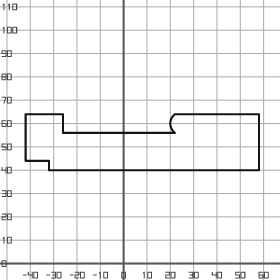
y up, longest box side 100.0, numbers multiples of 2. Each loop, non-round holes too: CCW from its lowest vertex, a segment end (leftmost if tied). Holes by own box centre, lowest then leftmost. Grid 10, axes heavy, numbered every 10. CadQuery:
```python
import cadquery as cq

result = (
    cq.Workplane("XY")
    .moveTo(-32.0, 40.0)
    .lineTo(58.0, 40.0)
    .lineTo(58.0, 64.0)
    .lineTo(22.0, 64.0)
    .threePointArc((20.0, 60.0), (22.0, 56.0))
    .lineTo(-26.0, 56.0)
    .lineTo(-26.0, 64.0)
    .lineTo(-42.0, 64.0)
    .lineTo(-42.0, 44.0)
    .lineTo(-32.0, 44.0)
    .close()
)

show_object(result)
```